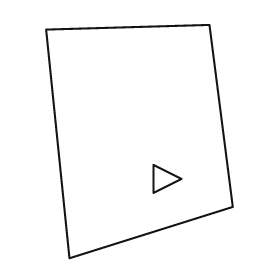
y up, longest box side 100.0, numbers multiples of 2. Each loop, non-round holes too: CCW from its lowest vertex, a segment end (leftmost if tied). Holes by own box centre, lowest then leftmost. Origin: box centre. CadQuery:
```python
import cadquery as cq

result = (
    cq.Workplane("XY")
    .moveTo(-30.0, -50.0)
    .lineTo(40.0, -28.0)
    .lineTo(30.0, 50.0)
    .lineTo(-40.0, 48.0)
    .close()
    .moveTo(6.0, -22.0)
    .lineTo(18.0, -16.0)
    .lineTo(6.0, -10.0)
    .close()
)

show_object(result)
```